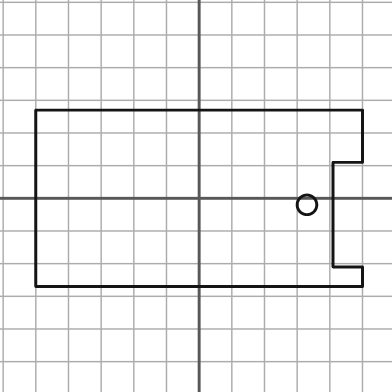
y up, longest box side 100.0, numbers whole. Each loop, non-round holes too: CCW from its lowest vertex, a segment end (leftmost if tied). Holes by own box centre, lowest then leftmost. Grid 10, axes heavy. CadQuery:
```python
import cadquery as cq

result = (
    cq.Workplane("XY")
    .moveTo(-50.0, -27.0)
    .lineTo(50.0, -27.0)
    .lineTo(50.0, -21.0)
    .lineTo(41.0, -21.0)
    .lineTo(41.0, 11.0)
    .lineTo(50.0, 11.0)
    .lineTo(50.0, 27.0)
    .lineTo(-50.0, 27.0)
    .close()
    .moveTo(33.0, -2.0)
    .circle(3.0)
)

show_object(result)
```